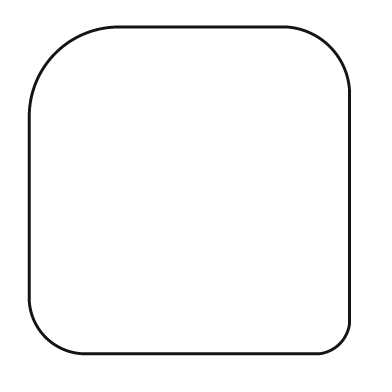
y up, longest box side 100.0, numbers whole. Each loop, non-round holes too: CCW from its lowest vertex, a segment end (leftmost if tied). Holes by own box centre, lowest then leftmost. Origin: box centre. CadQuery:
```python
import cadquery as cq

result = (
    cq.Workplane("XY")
    .moveTo(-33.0, -50.0)
    .lineTo(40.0, -50.0)
    .threePointArc((46.0, -47.0), (49.0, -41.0))
    .lineTo(49.0, 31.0)
    .threePointArc((43.0, 44.0), (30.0, 50.0))
    .lineTo(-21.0, 50.0)
    .threePointArc((-41.0, 42.0), (-49.0, 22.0))
    .lineTo(-49.0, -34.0)
    .threePointArc((-44.0, -45.0), (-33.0, -50.0))
    .close()
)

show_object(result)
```